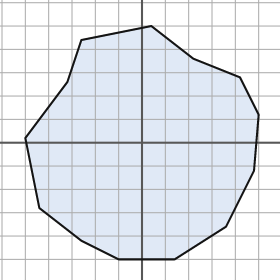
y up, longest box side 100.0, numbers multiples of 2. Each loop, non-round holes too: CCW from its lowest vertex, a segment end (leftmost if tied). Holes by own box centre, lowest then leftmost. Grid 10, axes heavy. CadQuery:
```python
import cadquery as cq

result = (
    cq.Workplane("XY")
    .moveTo(-10.0, -50.0)
    .lineTo(14.0, -50.0)
    .lineTo(36.0, -36.0)
    .lineTo(48.0, -12.0)
    .lineTo(50.0, 12.0)
    .lineTo(42.0, 28.0)
    .lineTo(22.0, 36.0)
    .lineTo(4.0, 50.0)
    .lineTo(-26.0, 44.0)
    .lineTo(-32.0, 26.0)
    .lineTo(-50.0, 2.0)
    .lineTo(-44.0, -28.0)
    .lineTo(-26.0, -42.0)
    .close()
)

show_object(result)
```